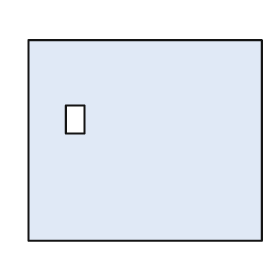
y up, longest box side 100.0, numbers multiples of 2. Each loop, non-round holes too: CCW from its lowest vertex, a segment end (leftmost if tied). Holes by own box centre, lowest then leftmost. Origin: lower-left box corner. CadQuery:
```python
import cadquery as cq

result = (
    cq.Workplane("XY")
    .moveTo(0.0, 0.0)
    .lineTo(100.0, 0.0)
    .lineTo(100.0, 86.0)
    .lineTo(0.0, 86.0)
    .close()
    .moveTo(16.0, 46.0)
    .lineTo(24.0, 46.0)
    .lineTo(24.0, 58.0)
    .lineTo(16.0, 58.0)
    .close()
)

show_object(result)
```